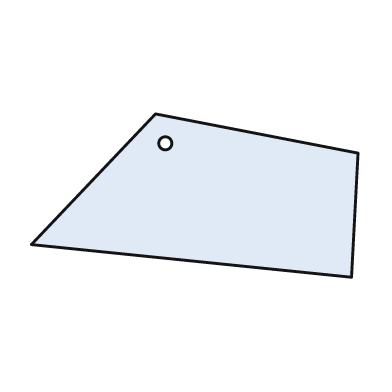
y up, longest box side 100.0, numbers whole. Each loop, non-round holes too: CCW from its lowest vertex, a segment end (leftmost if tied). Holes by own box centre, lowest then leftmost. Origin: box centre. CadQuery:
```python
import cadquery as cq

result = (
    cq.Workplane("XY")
    .moveTo(48.0, -25.0)
    .lineTo(50.0, 13.0)
    .lineTo(-12.0, 25.0)
    .lineTo(-50.0, -15.0)
    .close()
    .moveTo(-9.0, 16.0)
    .circle(2.0)
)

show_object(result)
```